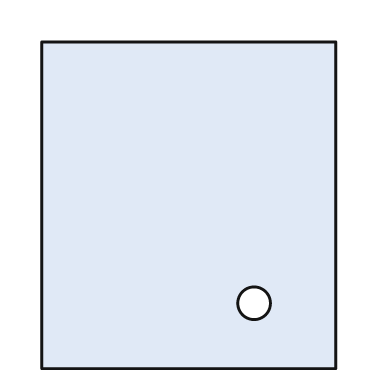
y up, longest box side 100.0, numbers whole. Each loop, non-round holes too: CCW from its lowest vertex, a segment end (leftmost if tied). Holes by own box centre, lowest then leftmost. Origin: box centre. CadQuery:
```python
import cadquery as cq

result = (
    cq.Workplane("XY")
    .moveTo(-45.0, -50.0)
    .lineTo(45.0, -50.0)
    .lineTo(45.0, 50.0)
    .lineTo(-45.0, 50.0)
    .close()
    .moveTo(20.0, -30.0)
    .circle(5.0)
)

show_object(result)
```